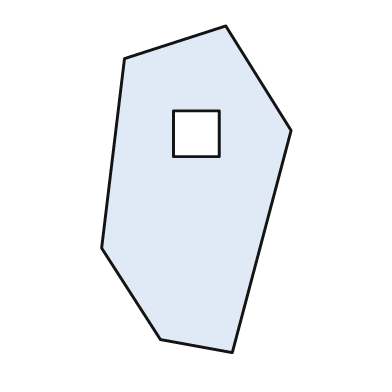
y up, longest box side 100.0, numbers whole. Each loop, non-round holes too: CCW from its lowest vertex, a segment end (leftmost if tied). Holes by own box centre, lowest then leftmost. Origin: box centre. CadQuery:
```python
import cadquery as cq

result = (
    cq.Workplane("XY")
    .moveTo(11.0, -50.0)
    .lineTo(29.0, 18.0)
    .lineTo(9.0, 50.0)
    .lineTo(-22.0, 40.0)
    .lineTo(-29.0, -18.0)
    .lineTo(-11.0, -46.0)
    .close()
    .moveTo(-7.0, 10.0)
    .lineTo(7.0, 10.0)
    .lineTo(7.0, 24.0)
    .lineTo(-7.0, 24.0)
    .close()
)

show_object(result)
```